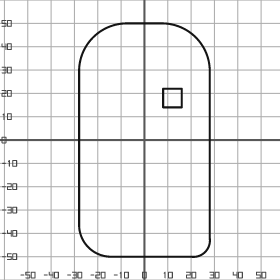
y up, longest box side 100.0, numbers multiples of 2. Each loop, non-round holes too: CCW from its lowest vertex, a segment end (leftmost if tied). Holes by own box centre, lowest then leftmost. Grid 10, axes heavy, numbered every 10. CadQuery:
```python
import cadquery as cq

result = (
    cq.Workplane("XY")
    .moveTo(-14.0, -50.0)
    .lineTo(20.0, -50.0)
    .threePointArc((26.0, -48.0), (28.0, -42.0))
    .lineTo(28.0, 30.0)
    .threePointArc((22.0, 44.0), (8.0, 50.0))
    .lineTo(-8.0, 50.0)
    .threePointArc((-22.0, 44.0), (-28.0, 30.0))
    .lineTo(-28.0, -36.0)
    .threePointArc((-24.0, -46.0), (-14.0, -50.0))
    .close()
    .moveTo(8.0, 14.0)
    .lineTo(16.0, 14.0)
    .lineTo(16.0, 22.0)
    .lineTo(8.0, 22.0)
    .close()
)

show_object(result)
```